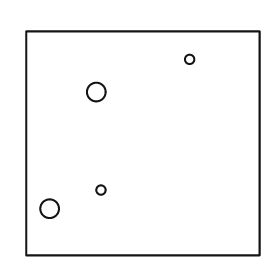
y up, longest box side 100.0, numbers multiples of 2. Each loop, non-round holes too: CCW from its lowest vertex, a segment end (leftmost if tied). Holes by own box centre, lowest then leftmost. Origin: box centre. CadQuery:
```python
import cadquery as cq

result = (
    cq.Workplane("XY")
    .moveTo(-50.0, -48.0)
    .lineTo(50.0, -48.0)
    .lineTo(50.0, 48.0)
    .lineTo(-50.0, 48.0)
    .close()
    .moveTo(-40.0, -28.0)
    .circle(4.0)
    .moveTo(-18.0, -20.0)
    .circle(2.0)
    .moveTo(-20.0, 22.0)
    .circle(4.0)
    .moveTo(20.0, 36.0)
    .circle(2.0)
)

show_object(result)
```